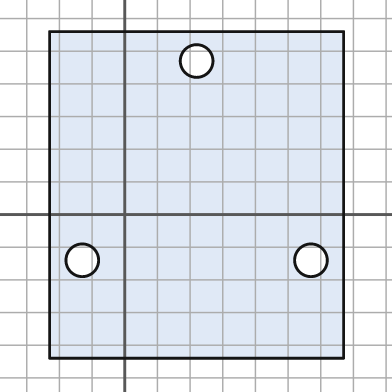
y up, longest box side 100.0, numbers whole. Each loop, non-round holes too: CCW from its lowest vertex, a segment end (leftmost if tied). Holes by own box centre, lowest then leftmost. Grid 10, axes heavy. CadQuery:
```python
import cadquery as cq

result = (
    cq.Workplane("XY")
    .moveTo(-23.0, -44.0)
    .lineTo(67.0, -44.0)
    .lineTo(67.0, 56.0)
    .lineTo(-23.0, 56.0)
    .close()
    .moveTo(-13.0, -14.0)
    .circle(5.0)
    .moveTo(57.0, -14.0)
    .circle(5.0)
    .moveTo(22.0, 47.0)
    .circle(5.0)
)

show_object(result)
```